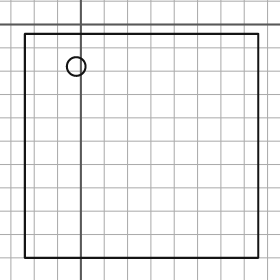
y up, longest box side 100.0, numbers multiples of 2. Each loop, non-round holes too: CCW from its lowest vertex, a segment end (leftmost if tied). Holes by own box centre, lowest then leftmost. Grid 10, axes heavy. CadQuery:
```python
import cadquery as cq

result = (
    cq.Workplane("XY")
    .moveTo(-24.0, -100.0)
    .lineTo(76.0, -100.0)
    .lineTo(76.0, -4.0)
    .lineTo(-24.0, -4.0)
    .close()
    .moveTo(-2.0, -18.0)
    .circle(4.0)
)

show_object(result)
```